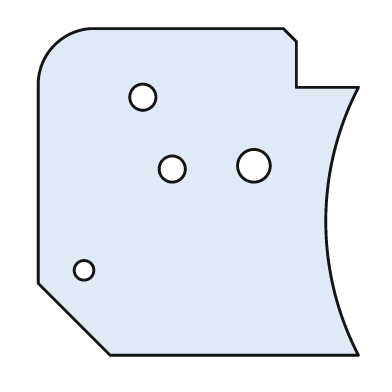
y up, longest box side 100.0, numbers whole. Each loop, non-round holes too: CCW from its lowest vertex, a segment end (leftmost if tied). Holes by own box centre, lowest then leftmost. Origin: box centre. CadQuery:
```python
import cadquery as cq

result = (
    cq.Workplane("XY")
    .moveTo(-27.0, -50.0)
    .lineTo(49.0, -50.0)
    .threePointArc((39.0, -9.0), (49.0, 32.0))
    .lineTo(30.0, 32.0)
    .lineTo(30.0, 46.0)
    .lineTo(26.0, 50.0)
    .lineTo(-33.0, 50.0)
    .threePointArc((-44.0, 45.0), (-49.0, 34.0))
    .lineTo(-49.0, -28.0)
    .close()
    .moveTo(-35.0, -24.0)
    .circle(3.0)
    .moveTo(-8.0, 7.0)
    .circle(4.0)
    .moveTo(17.0, 8.0)
    .circle(5.0)
    .moveTo(-17.0, 29.0)
    .circle(4.0)
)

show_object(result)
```